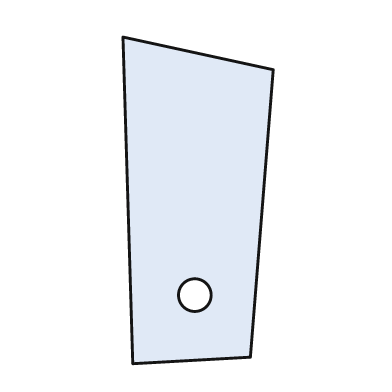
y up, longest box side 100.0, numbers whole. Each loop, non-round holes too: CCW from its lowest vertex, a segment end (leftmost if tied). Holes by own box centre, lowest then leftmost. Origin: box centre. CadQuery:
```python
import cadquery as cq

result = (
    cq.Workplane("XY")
    .moveTo(-20.0, -50.0)
    .lineTo(16.0, -48.0)
    .lineTo(23.0, 40.0)
    .lineTo(-23.0, 50.0)
    .close()
    .moveTo(-1.0, -29.0)
    .circle(5.0)
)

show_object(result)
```